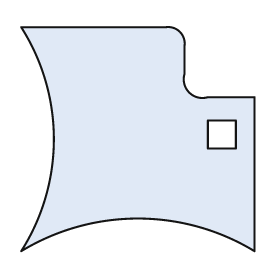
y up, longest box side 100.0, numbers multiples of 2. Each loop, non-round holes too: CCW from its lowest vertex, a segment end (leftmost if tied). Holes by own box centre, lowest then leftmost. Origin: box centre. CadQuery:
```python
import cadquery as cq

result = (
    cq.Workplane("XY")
    .moveTo(-50.0, -48.0)
    .threePointArc((0.0, -34.0), (50.0, -48.0))
    .lineTo(50.0, 18.0)
    .lineTo(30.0, 18.0)
    .threePointArc((22.0, 20.0), (20.0, 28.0))
    .lineTo(20.0, 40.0)
    .threePointArc((18.0, 46.0), (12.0, 48.0))
    .lineTo(-50.0, 48.0)
    .threePointArc((-36.0, 0.0), (-50.0, -48.0))
    .close()
    .moveTo(30.0, -4.0)
    .lineTo(42.0, -4.0)
    .lineTo(42.0, 8.0)
    .lineTo(30.0, 8.0)
    .close()
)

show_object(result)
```